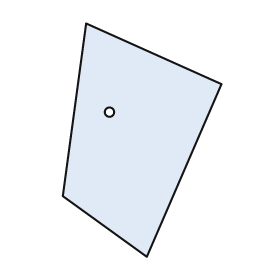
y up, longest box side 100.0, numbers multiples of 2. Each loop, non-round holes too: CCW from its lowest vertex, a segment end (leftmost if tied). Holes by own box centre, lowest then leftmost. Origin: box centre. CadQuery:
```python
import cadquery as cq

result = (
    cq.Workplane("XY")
    .moveTo(2.0, -50.0)
    .lineTo(34.0, 24.0)
    .lineTo(-24.0, 50.0)
    .lineTo(-34.0, -24.0)
    .close()
    .moveTo(-14.0, 12.0)
    .circle(2.0)
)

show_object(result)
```